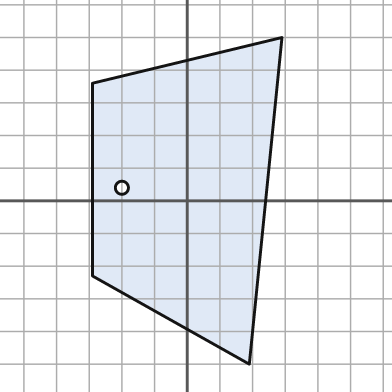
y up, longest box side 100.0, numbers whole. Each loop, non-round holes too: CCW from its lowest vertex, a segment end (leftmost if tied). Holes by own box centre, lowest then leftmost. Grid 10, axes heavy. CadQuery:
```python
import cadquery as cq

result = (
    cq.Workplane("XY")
    .moveTo(19.0, -50.0)
    .lineTo(29.0, 50.0)
    .lineTo(-29.0, 36.0)
    .lineTo(-29.0, -23.0)
    .close()
    .moveTo(-20.0, 4.0)
    .circle(2.0)
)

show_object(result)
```